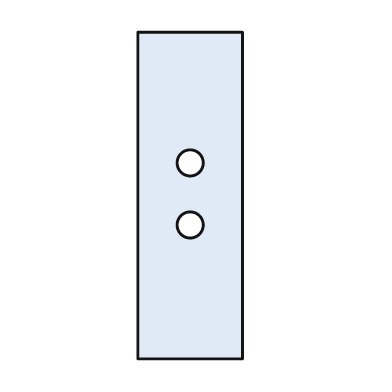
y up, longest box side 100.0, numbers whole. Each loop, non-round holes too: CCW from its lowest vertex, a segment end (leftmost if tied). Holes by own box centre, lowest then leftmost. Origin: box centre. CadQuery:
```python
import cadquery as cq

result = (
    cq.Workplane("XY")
    .moveTo(-16.0, -50.0)
    .lineTo(16.0, -50.0)
    .lineTo(16.0, 50.0)
    .lineTo(-16.0, 50.0)
    .close()
    .moveTo(0.0, -9.0)
    .circle(4.0)
    .moveTo(0.0, 10.0)
    .circle(4.0)
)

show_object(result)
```